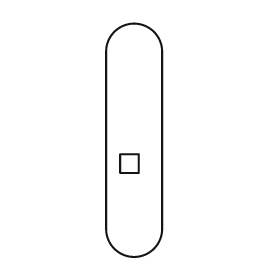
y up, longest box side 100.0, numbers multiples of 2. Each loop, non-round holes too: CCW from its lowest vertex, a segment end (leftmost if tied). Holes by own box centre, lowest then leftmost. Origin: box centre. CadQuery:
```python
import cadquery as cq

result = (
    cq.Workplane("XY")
    .moveTo(-12.0, -38.0)
    .threePointArc((0.0, -50.0), (12.0, -38.0))
    .lineTo(12.0, 38.0)
    .threePointArc((0.0, 50.0), (-12.0, 38.0))
    .close()
    .moveTo(-6.0, -14.0)
    .lineTo(2.0, -14.0)
    .lineTo(2.0, -6.0)
    .lineTo(-6.0, -6.0)
    .close()
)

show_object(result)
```